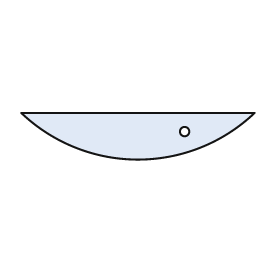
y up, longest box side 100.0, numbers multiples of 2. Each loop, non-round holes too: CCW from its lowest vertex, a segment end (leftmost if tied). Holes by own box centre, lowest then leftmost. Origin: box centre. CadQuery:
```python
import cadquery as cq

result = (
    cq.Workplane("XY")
    .moveTo(-50.0, 10.0)
    .threePointArc((0.0, -10.0), (50.0, 10.0))
    .close()
    .moveTo(20.0, 2.0)
    .circle(2.0)
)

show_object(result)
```